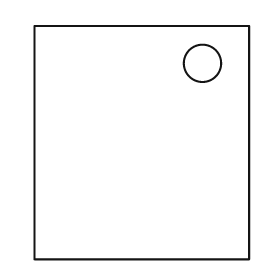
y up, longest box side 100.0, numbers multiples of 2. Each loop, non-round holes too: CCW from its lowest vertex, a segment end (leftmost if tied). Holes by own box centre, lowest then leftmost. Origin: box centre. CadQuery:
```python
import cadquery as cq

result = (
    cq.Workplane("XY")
    .moveTo(-46.0, -50.0)
    .lineTo(46.0, -50.0)
    .lineTo(46.0, 50.0)
    .lineTo(-46.0, 50.0)
    .close()
    .moveTo(26.0, 34.0)
    .circle(8.0)
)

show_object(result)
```